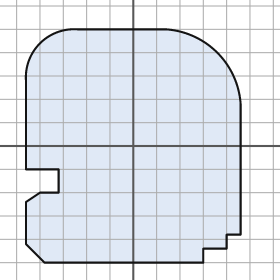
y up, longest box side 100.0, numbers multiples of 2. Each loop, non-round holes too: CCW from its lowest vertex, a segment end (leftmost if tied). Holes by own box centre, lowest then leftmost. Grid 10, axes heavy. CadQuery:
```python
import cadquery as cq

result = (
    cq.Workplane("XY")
    .moveTo(-38.0, -50.0)
    .lineTo(30.0, -50.0)
    .lineTo(30.0, -44.0)
    .lineTo(40.0, -44.0)
    .lineTo(40.0, -38.0)
    .lineTo(46.0, -38.0)
    .lineTo(46.0, 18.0)
    .threePointArc((36.0, 40.0), (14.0, 50.0))
    .lineTo(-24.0, 50.0)
    .threePointArc((-40.0, 44.0), (-46.0, 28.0))
    .lineTo(-46.0, -10.0)
    .lineTo(-32.0, -10.0)
    .lineTo(-32.0, -20.0)
    .lineTo(-40.0, -20.0)
    .lineTo(-46.0, -24.0)
    .lineTo(-46.0, -42.0)
    .close()
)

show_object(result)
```